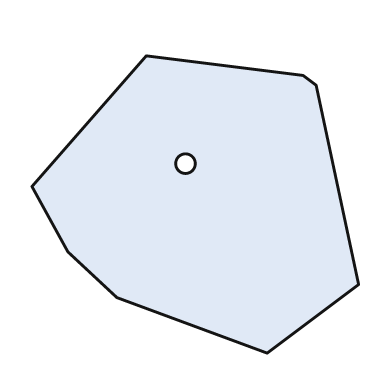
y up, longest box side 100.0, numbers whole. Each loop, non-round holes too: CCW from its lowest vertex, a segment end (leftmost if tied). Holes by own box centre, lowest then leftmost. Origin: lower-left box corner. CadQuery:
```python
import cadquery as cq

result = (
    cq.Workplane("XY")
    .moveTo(72.0, 0.0)
    .lineTo(100.0, 21.0)
    .lineTo(87.0, 82.0)
    .lineTo(83.0, 85.0)
    .lineTo(35.0, 91.0)
    .lineTo(0.0, 51.0)
    .lineTo(11.0, 31.0)
    .lineTo(26.0, 17.0)
    .close()
    .moveTo(47.0, 58.0)
    .circle(3.0)
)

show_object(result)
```